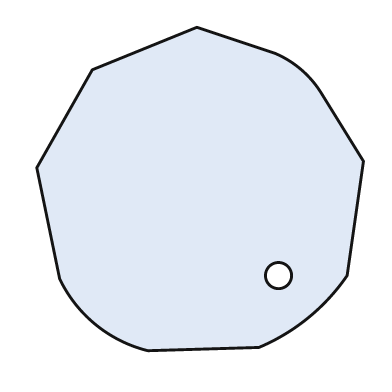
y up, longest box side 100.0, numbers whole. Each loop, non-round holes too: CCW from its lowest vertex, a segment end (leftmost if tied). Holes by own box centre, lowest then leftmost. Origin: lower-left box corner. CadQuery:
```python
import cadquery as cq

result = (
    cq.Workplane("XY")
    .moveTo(34.0, 0.0)
    .lineTo(68.0, 1.0)
    .threePointArc((83.0, 10.0), (95.0, 23.0))
    .lineTo(100.0, 58.0)
    .lineTo(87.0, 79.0)
    .threePointArc((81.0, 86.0), (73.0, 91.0))
    .lineTo(49.0, 99.0)
    .lineTo(17.0, 86.0)
    .lineTo(0.0, 56.0)
    .lineTo(7.0, 22.0)
    .threePointArc((18.0, 8.0), (34.0, 0.0))
    .close()
    .moveTo(74.0, 23.0)
    .circle(4.0)
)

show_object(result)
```